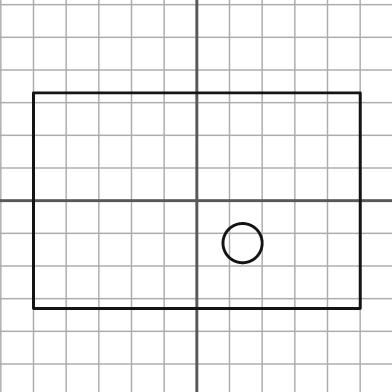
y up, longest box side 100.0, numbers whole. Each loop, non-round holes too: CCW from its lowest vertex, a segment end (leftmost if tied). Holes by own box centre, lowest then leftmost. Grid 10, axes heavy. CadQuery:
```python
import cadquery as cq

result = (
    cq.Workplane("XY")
    .moveTo(-50.0, -33.0)
    .lineTo(50.0, -33.0)
    .lineTo(50.0, 33.0)
    .lineTo(-50.0, 33.0)
    .close()
    .moveTo(14.0, -13.0)
    .circle(6.0)
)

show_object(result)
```